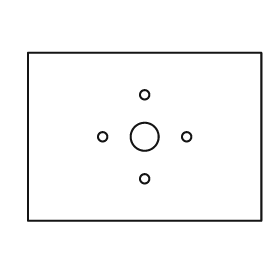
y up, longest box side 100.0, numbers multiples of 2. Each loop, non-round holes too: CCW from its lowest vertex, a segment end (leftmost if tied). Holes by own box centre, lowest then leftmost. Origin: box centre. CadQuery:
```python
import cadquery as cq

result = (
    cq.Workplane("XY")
    .moveTo(-50.0, -36.0)
    .lineTo(50.0, -36.0)
    .lineTo(50.0, 36.0)
    .lineTo(-50.0, 36.0)
    .close()
    .moveTo(0.0, -18.0)
    .circle(2.0)
    .moveTo(-18.0, 0.0)
    .circle(2.0)
    .moveTo(0.0, 0.0)
    .circle(6.0)
    .moveTo(18.0, 0.0)
    .circle(2.0)
    .moveTo(0.0, 18.0)
    .circle(2.0)
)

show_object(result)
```